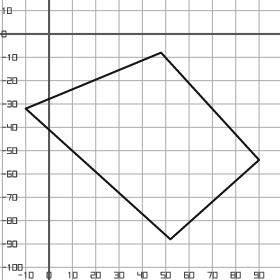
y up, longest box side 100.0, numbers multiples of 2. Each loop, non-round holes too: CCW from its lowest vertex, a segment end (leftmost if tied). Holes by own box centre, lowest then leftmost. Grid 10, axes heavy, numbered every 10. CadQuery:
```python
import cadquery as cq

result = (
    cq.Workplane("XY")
    .moveTo(52.0, -88.0)
    .lineTo(90.0, -54.0)
    .lineTo(48.0, -8.0)
    .lineTo(-10.0, -32.0)
    .close()
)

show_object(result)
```